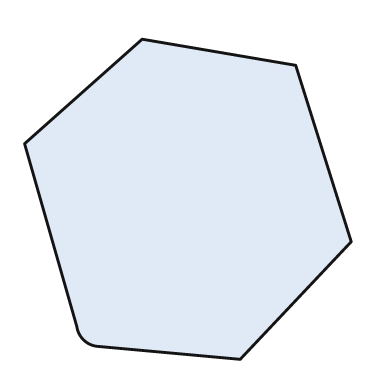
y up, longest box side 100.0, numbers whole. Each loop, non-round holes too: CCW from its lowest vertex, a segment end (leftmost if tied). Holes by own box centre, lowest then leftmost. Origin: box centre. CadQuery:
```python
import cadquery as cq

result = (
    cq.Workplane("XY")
    .moveTo(16.0, -49.0)
    .lineTo(50.0, -13.0)
    .lineTo(33.0, 41.0)
    .lineTo(-14.0, 49.0)
    .lineTo(-50.0, 17.0)
    .lineTo(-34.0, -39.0)
    .threePointArc((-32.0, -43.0), (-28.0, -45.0))
    .close()
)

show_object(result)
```